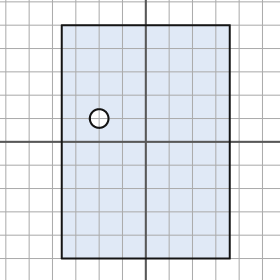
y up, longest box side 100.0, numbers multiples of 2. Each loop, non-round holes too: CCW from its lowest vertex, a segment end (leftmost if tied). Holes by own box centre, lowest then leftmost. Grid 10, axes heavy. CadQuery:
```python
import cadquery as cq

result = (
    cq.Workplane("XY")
    .moveTo(-36.0, -50.0)
    .lineTo(36.0, -50.0)
    .lineTo(36.0, 50.0)
    .lineTo(-36.0, 50.0)
    .close()
    .moveTo(-20.0, 10.0)
    .circle(4.0)
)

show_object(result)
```